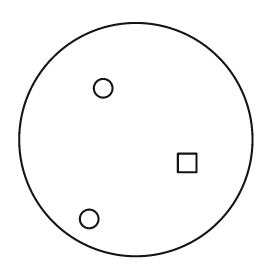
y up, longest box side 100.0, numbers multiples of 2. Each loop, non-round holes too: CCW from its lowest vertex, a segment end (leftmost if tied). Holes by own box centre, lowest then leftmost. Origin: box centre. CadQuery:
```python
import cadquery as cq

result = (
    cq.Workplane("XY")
    .moveTo(0.0, 0.0)
    .circle(50.0)
    .moveTo(-20.0, -34.0)
    .circle(4.0)
    .moveTo(18.0, -14.0)
    .lineTo(26.0, -14.0)
    .lineTo(26.0, -6.0)
    .lineTo(18.0, -6.0)
    .close()
    .moveTo(-14.0, 22.0)
    .circle(4.0)
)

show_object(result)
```